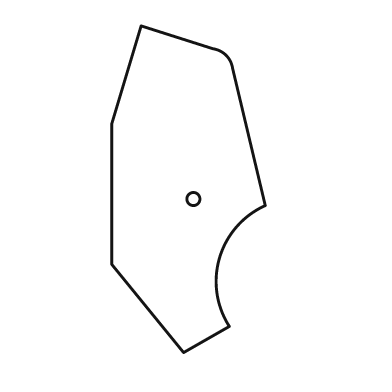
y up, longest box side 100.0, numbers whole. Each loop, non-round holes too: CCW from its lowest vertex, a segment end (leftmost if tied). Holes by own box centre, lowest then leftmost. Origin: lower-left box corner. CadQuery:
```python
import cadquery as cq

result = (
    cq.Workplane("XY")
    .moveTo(22.0, 0.0)
    .lineTo(36.0, 8.0)
    .threePointArc((33.0, 29.0), (47.0, 45.0))
    .lineTo(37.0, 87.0)
    .threePointArc((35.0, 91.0), (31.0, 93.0))
    .lineTo(9.0, 100.0)
    .lineTo(0.0, 70.0)
    .lineTo(0.0, 27.0)
    .close()
    .moveTo(25.0, 47.0)
    .circle(2.0)
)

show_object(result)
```